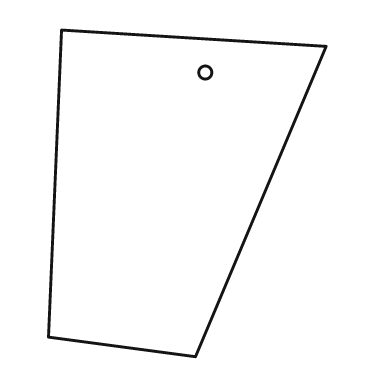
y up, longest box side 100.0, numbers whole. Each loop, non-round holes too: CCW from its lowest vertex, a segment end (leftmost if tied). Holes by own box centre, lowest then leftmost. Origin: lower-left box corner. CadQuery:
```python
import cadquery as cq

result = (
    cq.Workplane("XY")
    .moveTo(45.0, 0.0)
    .lineTo(85.0, 95.0)
    .lineTo(4.0, 100.0)
    .lineTo(0.0, 6.0)
    .close()
    .moveTo(48.0, 87.0)
    .circle(2.0)
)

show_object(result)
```